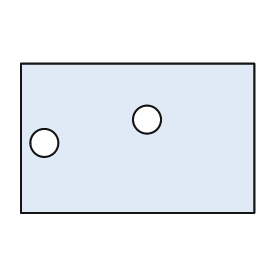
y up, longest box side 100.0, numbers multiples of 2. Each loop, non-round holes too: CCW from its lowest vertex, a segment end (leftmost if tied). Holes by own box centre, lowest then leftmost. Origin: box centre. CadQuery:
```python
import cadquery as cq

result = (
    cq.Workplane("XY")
    .moveTo(-50.0, -32.0)
    .lineTo(50.0, -32.0)
    .lineTo(50.0, 32.0)
    .lineTo(-50.0, 32.0)
    .close()
    .moveTo(-40.0, -2.0)
    .circle(6.0)
    .moveTo(4.0, 8.0)
    .circle(6.0)
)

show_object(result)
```